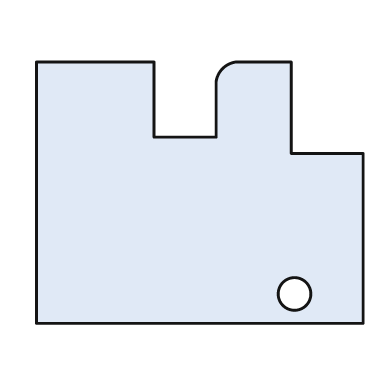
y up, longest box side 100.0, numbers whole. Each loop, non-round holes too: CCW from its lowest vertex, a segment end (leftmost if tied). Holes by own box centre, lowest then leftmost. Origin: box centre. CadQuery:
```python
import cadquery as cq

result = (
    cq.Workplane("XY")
    .moveTo(-50.0, -40.0)
    .lineTo(50.0, -40.0)
    .lineTo(50.0, 12.0)
    .lineTo(28.0, 12.0)
    .lineTo(28.0, 40.0)
    .lineTo(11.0, 40.0)
    .threePointArc((7.0, 38.0), (5.0, 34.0))
    .lineTo(5.0, 17.0)
    .lineTo(-14.0, 17.0)
    .lineTo(-14.0, 40.0)
    .lineTo(-50.0, 40.0)
    .close()
    .moveTo(29.0, -31.0)
    .circle(5.0)
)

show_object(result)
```